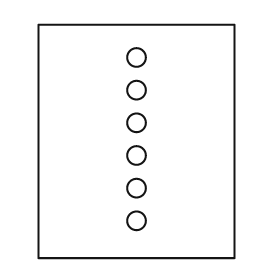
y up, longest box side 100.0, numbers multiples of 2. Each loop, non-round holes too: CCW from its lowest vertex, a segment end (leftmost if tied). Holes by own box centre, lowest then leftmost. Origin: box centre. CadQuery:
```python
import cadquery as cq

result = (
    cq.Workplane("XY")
    .moveTo(-42.0, -50.0)
    .lineTo(42.0, -50.0)
    .lineTo(42.0, 50.0)
    .lineTo(-42.0, 50.0)
    .close()
    .moveTo(0.0, -34.0)
    .circle(4.0)
    .moveTo(0.0, -20.0)
    .circle(4.0)
    .moveTo(0.0, -6.0)
    .circle(4.0)
    .moveTo(0.0, 8.0)
    .circle(4.0)
    .moveTo(0.0, 22.0)
    .circle(4.0)
    .moveTo(0.0, 36.0)
    .circle(4.0)
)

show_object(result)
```